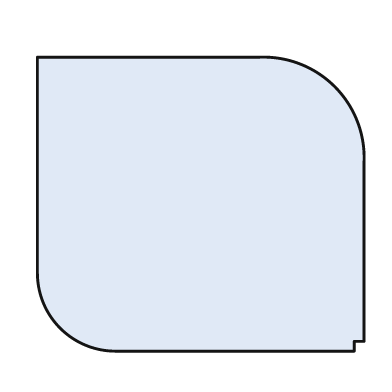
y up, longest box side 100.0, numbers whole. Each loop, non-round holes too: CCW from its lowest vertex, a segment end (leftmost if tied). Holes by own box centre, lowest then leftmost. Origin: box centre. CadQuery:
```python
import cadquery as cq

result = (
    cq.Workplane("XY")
    .moveTo(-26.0, -45.0)
    .lineTo(47.0, -45.0)
    .lineTo(47.0, -42.0)
    .lineTo(50.0, -42.0)
    .lineTo(50.0, 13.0)
    .threePointArc((41.0, 36.0), (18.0, 45.0))
    .lineTo(-50.0, 45.0)
    .lineTo(-50.0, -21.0)
    .threePointArc((-43.0, -38.0), (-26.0, -45.0))
    .close()
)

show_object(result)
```